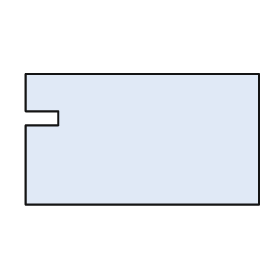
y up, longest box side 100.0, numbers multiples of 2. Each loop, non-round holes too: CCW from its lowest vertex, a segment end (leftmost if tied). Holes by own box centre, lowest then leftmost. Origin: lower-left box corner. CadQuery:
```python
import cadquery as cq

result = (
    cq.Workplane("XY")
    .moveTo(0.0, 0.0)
    .lineTo(100.0, 0.0)
    .lineTo(100.0, 56.0)
    .lineTo(0.0, 56.0)
    .lineTo(0.0, 40.0)
    .lineTo(14.0, 40.0)
    .lineTo(14.0, 34.0)
    .lineTo(0.0, 34.0)
    .close()
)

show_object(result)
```